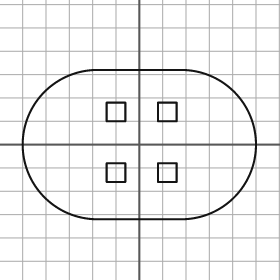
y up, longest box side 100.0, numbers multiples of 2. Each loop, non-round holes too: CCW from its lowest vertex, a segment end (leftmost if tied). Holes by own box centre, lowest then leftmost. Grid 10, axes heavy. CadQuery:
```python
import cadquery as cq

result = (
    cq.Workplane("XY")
    .moveTo(-18.0, -32.0)
    .lineTo(18.0, -32.0)
    .threePointArc((50.0, 0.0), (18.0, 32.0))
    .lineTo(-18.0, 32.0)
    .threePointArc((-50.0, 0.0), (-18.0, -32.0))
    .close()
    .moveTo(-14.0, -16.0)
    .lineTo(-6.0, -16.0)
    .lineTo(-6.0, -8.0)
    .lineTo(-14.0, -8.0)
    .close()
    .moveTo(8.0, -16.0)
    .lineTo(16.0, -16.0)
    .lineTo(16.0, -8.0)
    .lineTo(8.0, -8.0)
    .close()
    .moveTo(-14.0, 10.0)
    .lineTo(-6.0, 10.0)
    .lineTo(-6.0, 18.0)
    .lineTo(-14.0, 18.0)
    .close()
    .moveTo(8.0, 10.0)
    .lineTo(16.0, 10.0)
    .lineTo(16.0, 18.0)
    .lineTo(8.0, 18.0)
    .close()
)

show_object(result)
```